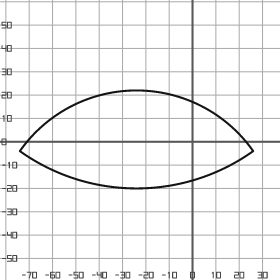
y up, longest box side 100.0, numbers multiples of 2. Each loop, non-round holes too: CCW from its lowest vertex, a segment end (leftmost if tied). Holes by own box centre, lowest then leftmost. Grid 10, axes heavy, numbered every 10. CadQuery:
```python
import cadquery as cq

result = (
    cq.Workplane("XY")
    .moveTo(-74.0, -4.0)
    .threePointArc((-24.0, -20.0), (26.0, -4.0))
    .threePointArc((-24.0, 22.0), (-74.0, -4.0))
    .close()
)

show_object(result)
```